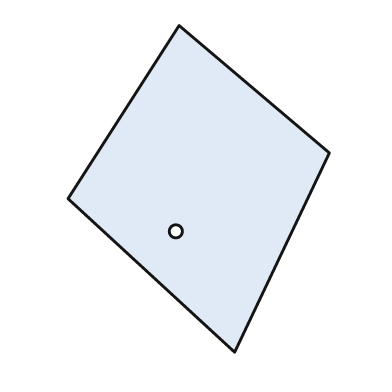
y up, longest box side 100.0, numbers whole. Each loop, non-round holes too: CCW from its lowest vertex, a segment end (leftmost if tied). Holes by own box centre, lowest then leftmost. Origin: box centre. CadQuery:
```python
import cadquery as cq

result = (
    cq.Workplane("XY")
    .moveTo(11.0, -50.0)
    .lineTo(40.0, 11.0)
    .lineTo(-6.0, 50.0)
    .lineTo(-40.0, -3.0)
    .close()
    .moveTo(-7.0, -13.0)
    .circle(2.0)
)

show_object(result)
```